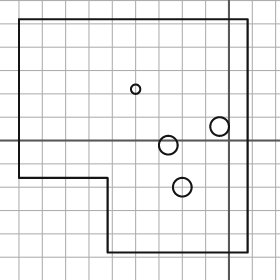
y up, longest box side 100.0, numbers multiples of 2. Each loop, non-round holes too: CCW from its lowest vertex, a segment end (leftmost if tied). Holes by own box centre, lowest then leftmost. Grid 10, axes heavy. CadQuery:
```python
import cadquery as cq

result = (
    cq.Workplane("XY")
    .moveTo(-52.0, -48.0)
    .lineTo(8.0, -48.0)
    .lineTo(8.0, 52.0)
    .lineTo(-90.0, 52.0)
    .lineTo(-90.0, -16.0)
    .lineTo(-52.0, -16.0)
    .close()
    .moveTo(-20.0, -20.0)
    .circle(4.0)
    .moveTo(-26.0, -2.0)
    .circle(4.0)
    .moveTo(-4.0, 6.0)
    .circle(4.0)
    .moveTo(-40.0, 22.0)
    .circle(2.0)
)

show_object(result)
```